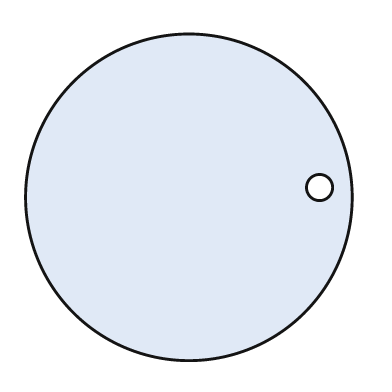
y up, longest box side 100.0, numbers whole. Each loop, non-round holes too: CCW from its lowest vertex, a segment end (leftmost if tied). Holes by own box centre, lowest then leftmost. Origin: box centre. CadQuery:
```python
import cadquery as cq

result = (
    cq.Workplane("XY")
    .moveTo(0.0, 0.0)
    .circle(50.0)
    .moveTo(40.0, 3.0)
    .circle(4.0)
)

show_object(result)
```